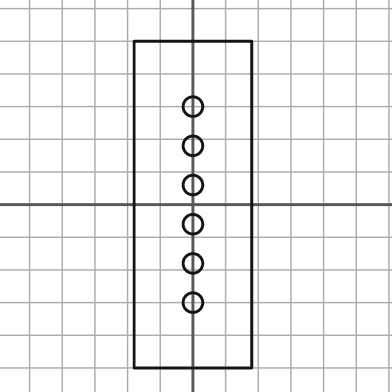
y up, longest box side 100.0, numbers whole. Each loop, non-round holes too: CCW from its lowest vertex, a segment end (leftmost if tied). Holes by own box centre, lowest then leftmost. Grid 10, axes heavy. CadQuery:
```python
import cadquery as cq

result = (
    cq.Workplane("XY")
    .moveTo(-18.0, -50.0)
    .lineTo(18.0, -50.0)
    .lineTo(18.0, 50.0)
    .lineTo(-18.0, 50.0)
    .close()
    .moveTo(0.0, -30.0)
    .circle(3.0)
    .moveTo(0.0, -18.0)
    .circle(3.0)
    .moveTo(0.0, -6.0)
    .circle(3.0)
    .moveTo(0.0, 6.0)
    .circle(3.0)
    .moveTo(0.0, 18.0)
    .circle(3.0)
    .moveTo(0.0, 30.0)
    .circle(3.0)
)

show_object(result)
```